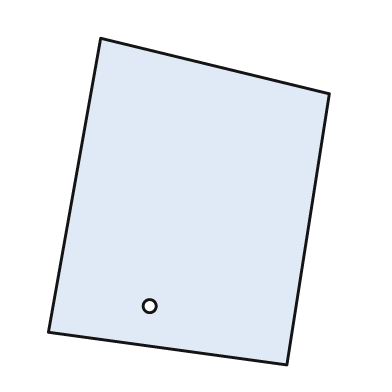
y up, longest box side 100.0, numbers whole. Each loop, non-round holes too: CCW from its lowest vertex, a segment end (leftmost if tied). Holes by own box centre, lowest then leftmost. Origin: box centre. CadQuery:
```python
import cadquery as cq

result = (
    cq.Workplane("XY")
    .moveTo(30.0, -50.0)
    .lineTo(43.0, 33.0)
    .lineTo(-27.0, 50.0)
    .lineTo(-43.0, -40.0)
    .close()
    .moveTo(-12.0, -32.0)
    .circle(2.0)
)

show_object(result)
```